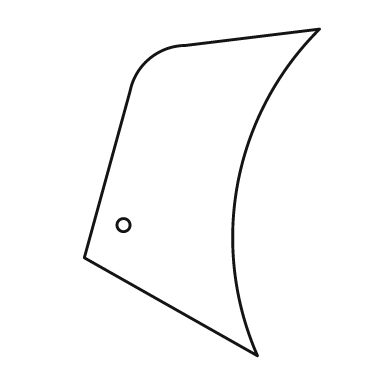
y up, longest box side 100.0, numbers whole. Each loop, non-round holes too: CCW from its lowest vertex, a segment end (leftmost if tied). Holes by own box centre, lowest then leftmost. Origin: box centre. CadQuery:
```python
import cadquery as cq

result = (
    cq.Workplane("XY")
    .moveTo(17.0, -50.0)
    .threePointArc((11.0, 3.0), (36.0, 50.0))
    .lineTo(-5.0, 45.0)
    .threePointArc((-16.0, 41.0), (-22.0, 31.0))
    .lineTo(-36.0, -20.0)
    .close()
    .moveTo(-24.0, -10.0)
    .circle(2.0)
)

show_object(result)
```